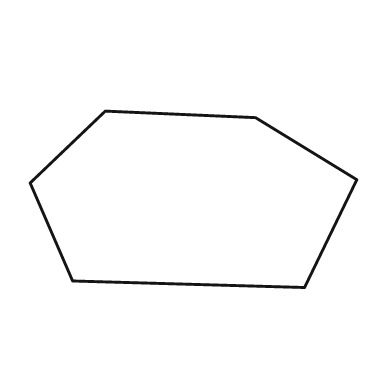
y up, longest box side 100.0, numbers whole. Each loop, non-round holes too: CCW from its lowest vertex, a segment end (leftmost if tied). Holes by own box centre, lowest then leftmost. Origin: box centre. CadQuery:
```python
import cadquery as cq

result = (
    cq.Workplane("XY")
    .moveTo(34.0, -27.0)
    .lineTo(50.0, 6.0)
    .lineTo(19.0, 25.0)
    .lineTo(-27.0, 27.0)
    .lineTo(-50.0, 5.0)
    .lineTo(-37.0, -25.0)
    .close()
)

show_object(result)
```